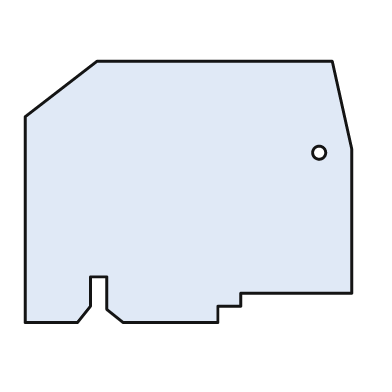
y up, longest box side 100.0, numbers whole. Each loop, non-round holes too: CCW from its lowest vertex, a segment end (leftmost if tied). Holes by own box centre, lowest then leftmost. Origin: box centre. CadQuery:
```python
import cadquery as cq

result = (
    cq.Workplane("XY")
    .moveTo(-50.0, -40.0)
    .lineTo(-34.0, -40.0)
    .lineTo(-30.0, -35.0)
    .lineTo(-30.0, -26.0)
    .lineTo(-25.0, -26.0)
    .lineTo(-25.0, -36.0)
    .lineTo(-20.0, -40.0)
    .lineTo(9.0, -40.0)
    .lineTo(9.0, -35.0)
    .lineTo(16.0, -35.0)
    .lineTo(16.0, -31.0)
    .lineTo(50.0, -31.0)
    .lineTo(50.0, 13.0)
    .lineTo(44.0, 40.0)
    .lineTo(-28.0, 40.0)
    .lineTo(-50.0, 23.0)
    .close()
    .moveTo(40.0, 12.0)
    .circle(2.0)
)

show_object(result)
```